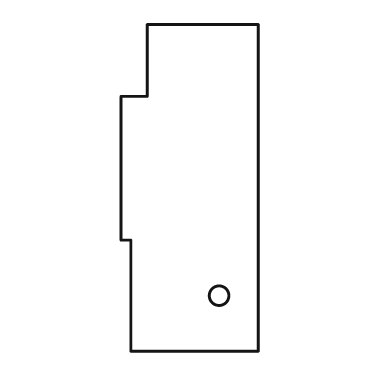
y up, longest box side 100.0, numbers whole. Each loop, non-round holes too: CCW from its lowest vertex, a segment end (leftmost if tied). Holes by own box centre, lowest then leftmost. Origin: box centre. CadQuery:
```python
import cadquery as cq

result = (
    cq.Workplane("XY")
    .moveTo(-18.0, -50.0)
    .lineTo(21.0, -50.0)
    .lineTo(21.0, 50.0)
    .lineTo(-13.0, 50.0)
    .lineTo(-13.0, 28.0)
    .lineTo(-21.0, 28.0)
    .lineTo(-21.0, -16.0)
    .lineTo(-18.0, -16.0)
    .close()
    .moveTo(9.0, -33.0)
    .circle(3.0)
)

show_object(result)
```